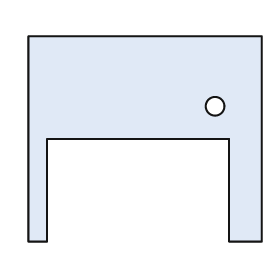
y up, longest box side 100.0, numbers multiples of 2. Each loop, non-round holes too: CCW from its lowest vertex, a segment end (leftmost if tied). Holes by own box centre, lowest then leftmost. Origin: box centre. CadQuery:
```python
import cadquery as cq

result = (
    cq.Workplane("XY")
    .moveTo(-50.0, -44.0)
    .lineTo(-42.0, -44.0)
    .lineTo(-42.0, 0.0)
    .lineTo(36.0, 0.0)
    .lineTo(36.0, -44.0)
    .lineTo(50.0, -44.0)
    .lineTo(50.0, 44.0)
    .lineTo(-50.0, 44.0)
    .close()
    .moveTo(30.0, 14.0)
    .circle(4.0)
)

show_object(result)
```